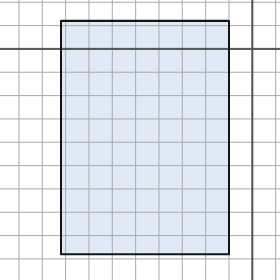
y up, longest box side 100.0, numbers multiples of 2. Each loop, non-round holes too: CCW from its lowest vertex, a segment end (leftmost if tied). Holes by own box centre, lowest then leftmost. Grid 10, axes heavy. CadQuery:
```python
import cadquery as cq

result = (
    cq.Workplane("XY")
    .moveTo(-82.0, -88.0)
    .lineTo(-10.0, -88.0)
    .lineTo(-10.0, 12.0)
    .lineTo(-82.0, 12.0)
    .close()
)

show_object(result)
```